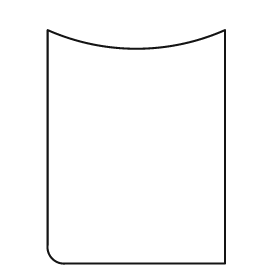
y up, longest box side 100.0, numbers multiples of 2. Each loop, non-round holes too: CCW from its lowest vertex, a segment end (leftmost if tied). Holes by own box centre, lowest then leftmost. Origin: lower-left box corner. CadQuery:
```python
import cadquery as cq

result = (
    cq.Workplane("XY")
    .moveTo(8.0, 0.0)
    .lineTo(76.0, 0.0)
    .lineTo(76.0, 100.0)
    .threePointArc((38.0, 92.0), (0.0, 100.0))
    .lineTo(0.0, 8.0)
    .threePointArc((2.0, 2.0), (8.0, 0.0))
    .close()
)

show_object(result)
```